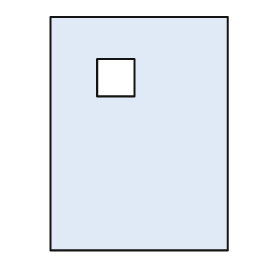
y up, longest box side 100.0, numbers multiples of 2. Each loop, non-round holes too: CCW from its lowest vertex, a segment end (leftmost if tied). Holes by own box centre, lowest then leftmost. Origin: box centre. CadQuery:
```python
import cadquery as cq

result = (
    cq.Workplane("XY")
    .moveTo(-38.0, -50.0)
    .lineTo(38.0, -50.0)
    .lineTo(38.0, 50.0)
    .lineTo(-38.0, 50.0)
    .close()
    .moveTo(-18.0, 16.0)
    .lineTo(-2.0, 16.0)
    .lineTo(-2.0, 32.0)
    .lineTo(-18.0, 32.0)
    .close()
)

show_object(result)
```